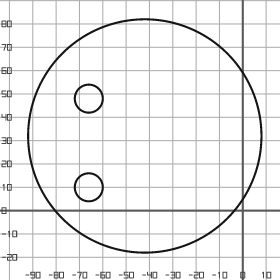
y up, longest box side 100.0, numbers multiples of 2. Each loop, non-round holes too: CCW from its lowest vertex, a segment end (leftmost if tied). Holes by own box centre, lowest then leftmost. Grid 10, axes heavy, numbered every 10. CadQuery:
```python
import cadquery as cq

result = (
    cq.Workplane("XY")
    .moveTo(-42.0, 32.0)
    .circle(50.0)
    .moveTo(-66.0, 10.0)
    .circle(6.0)
    .moveTo(-66.0, 48.0)
    .circle(6.0)
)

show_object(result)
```